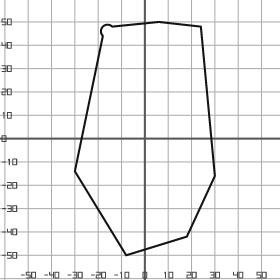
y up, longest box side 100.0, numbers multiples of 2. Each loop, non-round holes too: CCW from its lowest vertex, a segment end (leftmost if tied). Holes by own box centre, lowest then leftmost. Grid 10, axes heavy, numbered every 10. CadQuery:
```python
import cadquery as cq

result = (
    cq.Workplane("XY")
    .moveTo(-8.0, -50.0)
    .lineTo(18.0, -42.0)
    .lineTo(30.0, -16.0)
    .lineTo(24.0, 48.0)
    .lineTo(6.0, 50.0)
    .lineTo(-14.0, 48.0)
    .threePointArc((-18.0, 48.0), (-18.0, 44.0))
    .lineTo(-30.0, -14.0)
    .close()
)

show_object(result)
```